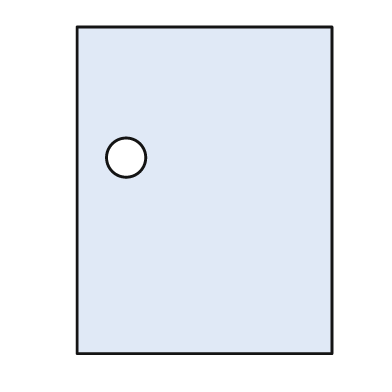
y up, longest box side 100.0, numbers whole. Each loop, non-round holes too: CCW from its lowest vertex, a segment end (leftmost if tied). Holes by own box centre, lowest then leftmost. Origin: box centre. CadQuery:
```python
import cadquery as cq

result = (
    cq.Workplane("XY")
    .moveTo(-39.0, -50.0)
    .lineTo(39.0, -50.0)
    .lineTo(39.0, 50.0)
    .lineTo(-39.0, 50.0)
    .close()
    .moveTo(-24.0, 10.0)
    .circle(6.0)
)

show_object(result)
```